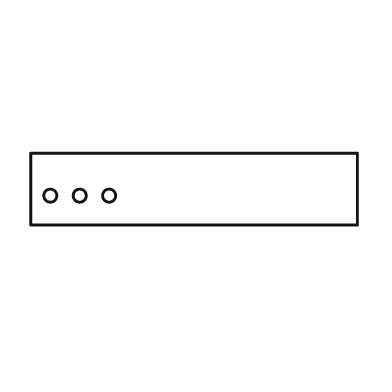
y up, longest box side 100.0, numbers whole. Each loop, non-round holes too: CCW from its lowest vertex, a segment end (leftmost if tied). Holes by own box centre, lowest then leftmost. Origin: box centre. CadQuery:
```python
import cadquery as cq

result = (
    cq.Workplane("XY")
    .moveTo(-50.0, -11.0)
    .lineTo(50.0, -11.0)
    .lineTo(50.0, 11.0)
    .lineTo(-50.0, 11.0)
    .close()
    .moveTo(-44.0, -2.0)
    .circle(2.0)
    .moveTo(-35.0, -2.0)
    .circle(2.0)
    .moveTo(-26.0, -2.0)
    .circle(2.0)
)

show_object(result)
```